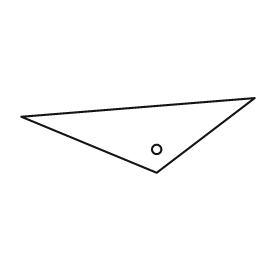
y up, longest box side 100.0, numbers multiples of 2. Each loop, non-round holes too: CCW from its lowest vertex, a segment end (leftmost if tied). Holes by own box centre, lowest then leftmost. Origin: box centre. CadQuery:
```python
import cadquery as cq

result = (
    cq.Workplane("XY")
    .moveTo(8.0, -16.0)
    .lineTo(50.0, 16.0)
    .lineTo(-50.0, 8.0)
    .close()
    .moveTo(8.0, -6.0)
    .circle(2.0)
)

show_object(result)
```